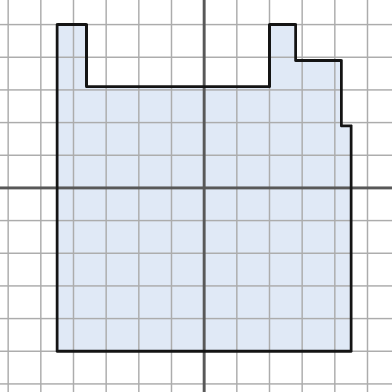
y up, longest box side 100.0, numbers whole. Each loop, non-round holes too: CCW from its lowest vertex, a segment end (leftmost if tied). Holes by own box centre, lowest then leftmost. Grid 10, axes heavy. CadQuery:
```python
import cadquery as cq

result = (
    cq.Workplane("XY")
    .moveTo(-45.0, -50.0)
    .lineTo(45.0, -50.0)
    .lineTo(45.0, 19.0)
    .lineTo(42.0, 19.0)
    .lineTo(42.0, 39.0)
    .lineTo(28.0, 39.0)
    .lineTo(28.0, 50.0)
    .lineTo(20.0, 50.0)
    .lineTo(20.0, 31.0)
    .lineTo(-36.0, 31.0)
    .lineTo(-36.0, 50.0)
    .lineTo(-45.0, 50.0)
    .close()
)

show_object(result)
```